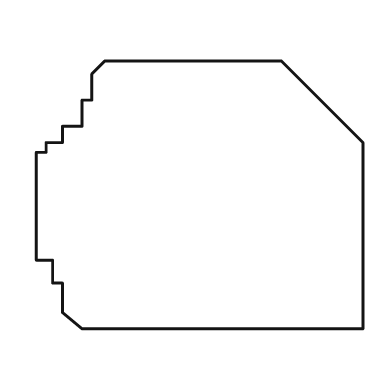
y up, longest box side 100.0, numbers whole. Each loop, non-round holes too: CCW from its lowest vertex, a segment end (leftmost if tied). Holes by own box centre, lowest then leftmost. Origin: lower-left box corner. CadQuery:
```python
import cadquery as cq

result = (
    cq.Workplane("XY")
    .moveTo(14.0, 0.0)
    .lineTo(100.0, 0.0)
    .lineTo(100.0, 57.0)
    .lineTo(75.0, 82.0)
    .lineTo(21.0, 82.0)
    .lineTo(17.0, 78.0)
    .lineTo(17.0, 70.0)
    .lineTo(14.0, 70.0)
    .lineTo(14.0, 62.0)
    .lineTo(8.0, 62.0)
    .lineTo(8.0, 57.0)
    .lineTo(3.0, 57.0)
    .lineTo(3.0, 54.0)
    .lineTo(0.0, 54.0)
    .lineTo(0.0, 21.0)
    .lineTo(5.0, 21.0)
    .lineTo(5.0, 14.0)
    .lineTo(8.0, 14.0)
    .lineTo(8.0, 5.0)
    .close()
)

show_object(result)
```